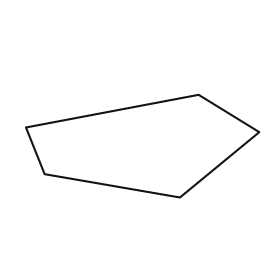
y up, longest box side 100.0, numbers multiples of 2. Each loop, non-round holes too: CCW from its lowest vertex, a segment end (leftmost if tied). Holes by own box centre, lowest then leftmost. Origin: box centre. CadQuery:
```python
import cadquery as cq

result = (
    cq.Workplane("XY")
    .moveTo(16.0, -22.0)
    .lineTo(50.0, 6.0)
    .lineTo(24.0, 22.0)
    .lineTo(-50.0, 8.0)
    .lineTo(-42.0, -12.0)
    .close()
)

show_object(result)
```